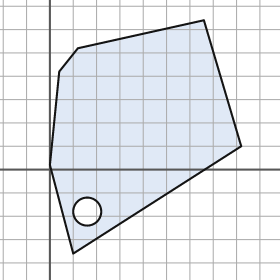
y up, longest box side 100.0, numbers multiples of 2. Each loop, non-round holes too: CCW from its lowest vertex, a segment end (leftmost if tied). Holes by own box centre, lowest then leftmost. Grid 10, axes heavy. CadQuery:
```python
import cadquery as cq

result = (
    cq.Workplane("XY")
    .moveTo(10.0, -36.0)
    .lineTo(82.0, 10.0)
    .lineTo(66.0, 64.0)
    .lineTo(12.0, 52.0)
    .lineTo(4.0, 42.0)
    .lineTo(0.0, 2.0)
    .close()
    .moveTo(16.0, -18.0)
    .circle(6.0)
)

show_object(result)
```